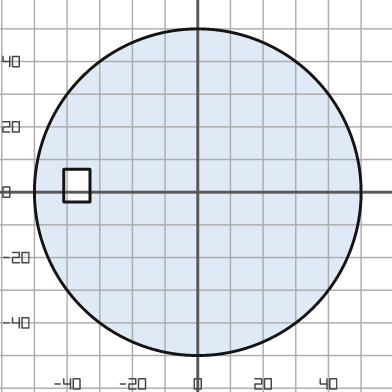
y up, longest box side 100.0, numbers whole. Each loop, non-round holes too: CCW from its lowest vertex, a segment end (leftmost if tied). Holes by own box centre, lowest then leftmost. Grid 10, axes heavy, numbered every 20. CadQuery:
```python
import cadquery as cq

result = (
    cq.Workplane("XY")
    .moveTo(0.0, 0.0)
    .circle(50.0)
    .moveTo(-41.0, -3.0)
    .lineTo(-33.0, -3.0)
    .lineTo(-33.0, 7.0)
    .lineTo(-41.0, 7.0)
    .close()
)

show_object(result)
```